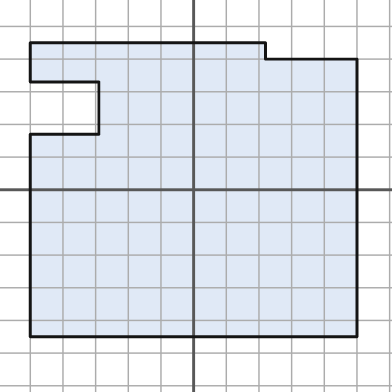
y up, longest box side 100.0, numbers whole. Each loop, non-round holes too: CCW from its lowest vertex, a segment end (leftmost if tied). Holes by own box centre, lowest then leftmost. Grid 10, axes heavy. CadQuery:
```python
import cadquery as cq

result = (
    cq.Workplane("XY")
    .moveTo(-50.0, -45.0)
    .lineTo(50.0, -45.0)
    .lineTo(50.0, 40.0)
    .lineTo(22.0, 40.0)
    .lineTo(22.0, 45.0)
    .lineTo(-50.0, 45.0)
    .lineTo(-50.0, 33.0)
    .lineTo(-29.0, 33.0)
    .lineTo(-29.0, 17.0)
    .lineTo(-50.0, 17.0)
    .close()
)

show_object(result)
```